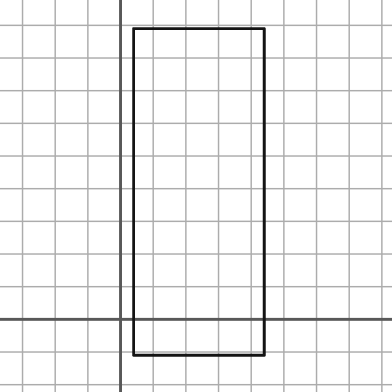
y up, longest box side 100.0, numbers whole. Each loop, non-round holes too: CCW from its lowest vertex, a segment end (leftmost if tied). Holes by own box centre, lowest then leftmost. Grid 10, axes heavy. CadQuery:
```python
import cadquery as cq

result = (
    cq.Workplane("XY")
    .moveTo(4.0, -11.0)
    .lineTo(44.0, -11.0)
    .lineTo(44.0, 89.0)
    .lineTo(4.0, 89.0)
    .close()
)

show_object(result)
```